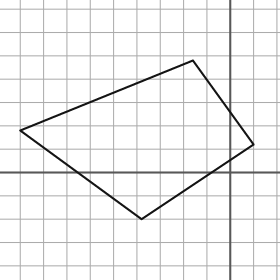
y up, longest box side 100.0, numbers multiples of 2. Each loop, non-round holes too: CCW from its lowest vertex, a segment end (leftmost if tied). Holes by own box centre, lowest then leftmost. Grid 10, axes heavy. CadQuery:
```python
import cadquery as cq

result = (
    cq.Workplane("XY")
    .moveTo(-38.0, -20.0)
    .lineTo(10.0, 12.0)
    .lineTo(-16.0, 48.0)
    .lineTo(-90.0, 18.0)
    .close()
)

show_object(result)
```